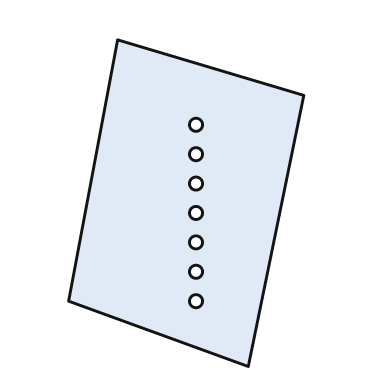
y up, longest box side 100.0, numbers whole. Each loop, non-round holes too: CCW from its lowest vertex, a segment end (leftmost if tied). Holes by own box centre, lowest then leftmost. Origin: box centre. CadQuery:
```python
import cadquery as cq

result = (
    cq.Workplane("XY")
    .moveTo(19.0, -50.0)
    .lineTo(36.0, 33.0)
    .lineTo(-21.0, 50.0)
    .lineTo(-36.0, -30.0)
    .close()
    .moveTo(3.0, -30.0)
    .circle(2.0)
    .moveTo(3.0, -21.0)
    .circle(2.0)
    .moveTo(3.0, -12.0)
    .circle(2.0)
    .moveTo(3.0, -3.0)
    .circle(2.0)
    .moveTo(3.0, 6.0)
    .circle(2.0)
    .moveTo(3.0, 15.0)
    .circle(2.0)
    .moveTo(3.0, 24.0)
    .circle(2.0)
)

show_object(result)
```